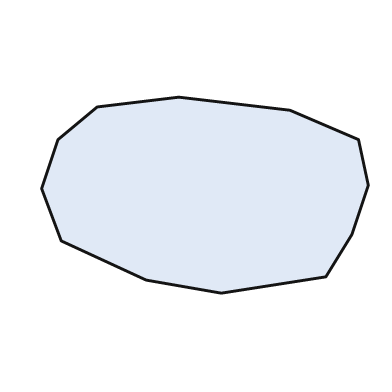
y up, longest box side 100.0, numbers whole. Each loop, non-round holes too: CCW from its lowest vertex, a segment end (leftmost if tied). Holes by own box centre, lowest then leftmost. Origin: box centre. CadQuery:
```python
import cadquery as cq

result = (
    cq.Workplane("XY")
    .moveTo(5.0, -30.0)
    .lineTo(37.0, -25.0)
    .lineTo(45.0, -12.0)
    .lineTo(50.0, 3.0)
    .lineTo(47.0, 17.0)
    .lineTo(26.0, 26.0)
    .lineTo(-8.0, 30.0)
    .lineTo(-33.0, 27.0)
    .lineTo(-45.0, 17.0)
    .lineTo(-50.0, 2.0)
    .lineTo(-44.0, -14.0)
    .lineTo(-18.0, -26.0)
    .close()
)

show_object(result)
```